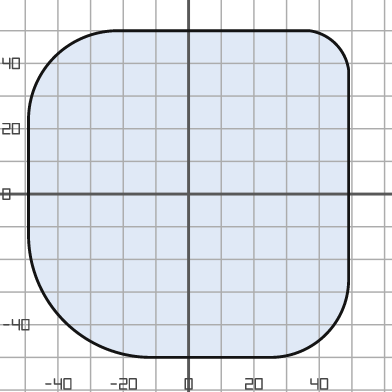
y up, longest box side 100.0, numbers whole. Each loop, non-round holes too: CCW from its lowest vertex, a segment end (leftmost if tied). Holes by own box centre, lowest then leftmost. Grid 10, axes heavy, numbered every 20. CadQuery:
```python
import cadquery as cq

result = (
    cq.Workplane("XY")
    .moveTo(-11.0, -50.0)
    .lineTo(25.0, -50.0)
    .threePointArc((42.0, -43.0), (49.0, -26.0))
    .lineTo(49.0, 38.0)
    .threePointArc((45.0, 46.0), (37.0, 50.0))
    .lineTo(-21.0, 50.0)
    .threePointArc((-41.0, 42.0), (-49.0, 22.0))
    .lineTo(-49.0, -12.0)
    .threePointArc((-38.0, -39.0), (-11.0, -50.0))
    .close()
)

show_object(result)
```